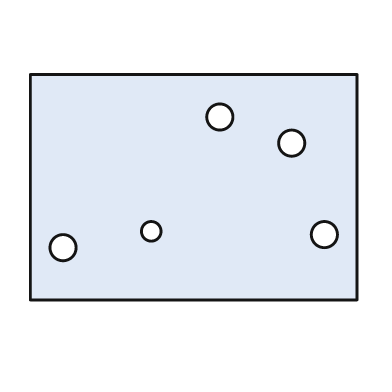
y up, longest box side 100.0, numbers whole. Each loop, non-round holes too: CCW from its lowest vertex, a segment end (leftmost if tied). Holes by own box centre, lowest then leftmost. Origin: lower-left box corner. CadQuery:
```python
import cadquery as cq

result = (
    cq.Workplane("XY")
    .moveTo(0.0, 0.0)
    .lineTo(100.0, 0.0)
    .lineTo(100.0, 69.0)
    .lineTo(0.0, 69.0)
    .close()
    .moveTo(10.0, 16.0)
    .circle(4.0)
    .moveTo(90.0, 20.0)
    .circle(4.0)
    .moveTo(37.0, 21.0)
    .circle(3.0)
    .moveTo(80.0, 48.0)
    .circle(4.0)
    .moveTo(58.0, 56.0)
    .circle(4.0)
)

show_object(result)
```